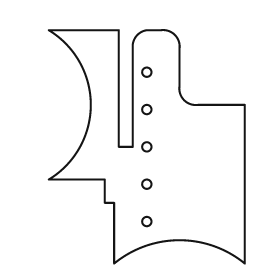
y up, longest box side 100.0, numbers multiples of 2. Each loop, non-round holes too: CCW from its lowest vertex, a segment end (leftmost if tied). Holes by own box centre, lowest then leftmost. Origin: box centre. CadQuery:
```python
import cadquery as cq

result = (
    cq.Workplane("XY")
    .moveTo(-14.0, -50.0)
    .threePointArc((14.0, -40.0), (42.0, -50.0))
    .lineTo(42.0, 18.0)
    .lineTo(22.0, 18.0)
    .threePointArc((16.0, 20.0), (14.0, 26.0))
    .lineTo(14.0, 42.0)
    .threePointArc((12.0, 48.0), (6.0, 50.0))
    .lineTo(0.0, 50.0)
    .threePointArc((-4.0, 48.0), (-6.0, 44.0))
    .lineTo(-6.0, 0.0)
    .lineTo(-12.0, 0.0)
    .lineTo(-12.0, 50.0)
    .lineTo(-42.0, 50.0)
    .threePointArc((-24.0, 18.0), (-42.0, -14.0))
    .lineTo(-18.0, -14.0)
    .lineTo(-18.0, -24.0)
    .lineTo(-14.0, -24.0)
    .close()
    .moveTo(0.0, -32.0)
    .circle(2.0)
    .moveTo(0.0, -16.0)
    .circle(2.0)
    .moveTo(0.0, 0.0)
    .circle(2.0)
    .moveTo(0.0, 16.0)
    .circle(2.0)
    .moveTo(0.0, 32.0)
    .circle(2.0)
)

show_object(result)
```